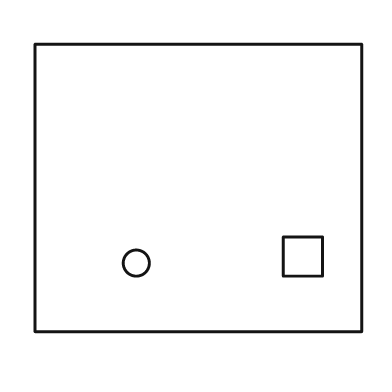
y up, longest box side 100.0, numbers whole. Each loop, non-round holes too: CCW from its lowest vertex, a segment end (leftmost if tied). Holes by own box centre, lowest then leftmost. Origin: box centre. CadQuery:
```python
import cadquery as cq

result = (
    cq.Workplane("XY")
    .moveTo(-50.0, -44.0)
    .lineTo(50.0, -44.0)
    .lineTo(50.0, 44.0)
    .lineTo(-50.0, 44.0)
    .close()
    .moveTo(-19.0, -23.0)
    .circle(4.0)
    .moveTo(26.0, -27.0)
    .lineTo(38.0, -27.0)
    .lineTo(38.0, -15.0)
    .lineTo(26.0, -15.0)
    .close()
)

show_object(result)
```